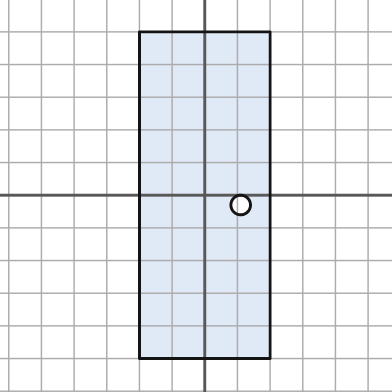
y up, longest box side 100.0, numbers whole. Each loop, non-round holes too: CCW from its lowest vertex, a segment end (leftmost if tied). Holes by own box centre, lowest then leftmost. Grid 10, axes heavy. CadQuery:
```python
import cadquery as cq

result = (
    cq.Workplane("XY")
    .moveTo(-20.0, -50.0)
    .lineTo(20.0, -50.0)
    .lineTo(20.0, 50.0)
    .lineTo(-20.0, 50.0)
    .close()
    .moveTo(11.0, -3.0)
    .circle(3.0)
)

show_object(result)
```